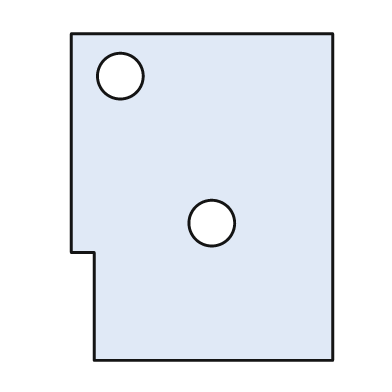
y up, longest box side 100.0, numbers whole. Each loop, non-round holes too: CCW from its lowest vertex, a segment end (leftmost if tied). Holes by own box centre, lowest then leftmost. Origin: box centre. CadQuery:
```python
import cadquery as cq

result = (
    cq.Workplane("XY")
    .moveTo(-33.0, -50.0)
    .lineTo(40.0, -50.0)
    .lineTo(40.0, 50.0)
    .lineTo(-40.0, 50.0)
    .lineTo(-40.0, -17.0)
    .lineTo(-33.0, -17.0)
    .close()
    .moveTo(3.0, -8.0)
    .circle(7.0)
    .moveTo(-25.0, 37.0)
    .circle(7.0)
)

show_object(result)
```